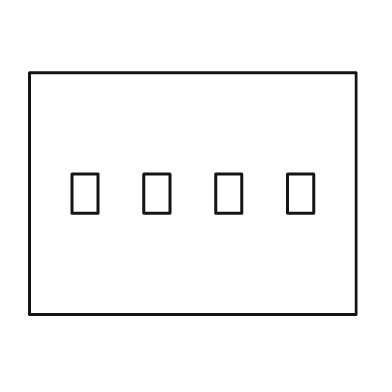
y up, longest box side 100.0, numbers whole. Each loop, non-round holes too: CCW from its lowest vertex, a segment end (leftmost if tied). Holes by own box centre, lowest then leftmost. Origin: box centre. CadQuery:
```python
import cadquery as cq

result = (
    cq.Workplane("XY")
    .moveTo(-50.0, -37.0)
    .lineTo(50.0, -37.0)
    .lineTo(50.0, 37.0)
    .lineTo(-50.0, 37.0)
    .close()
    .moveTo(-37.0, -6.0)
    .lineTo(-29.0, -6.0)
    .lineTo(-29.0, 6.0)
    .lineTo(-37.0, 6.0)
    .close()
    .moveTo(-15.0, -6.0)
    .lineTo(-7.0, -6.0)
    .lineTo(-7.0, 6.0)
    .lineTo(-15.0, 6.0)
    .close()
    .moveTo(7.0, -6.0)
    .lineTo(15.0, -6.0)
    .lineTo(15.0, 6.0)
    .lineTo(7.0, 6.0)
    .close()
    .moveTo(29.0, -6.0)
    .lineTo(37.0, -6.0)
    .lineTo(37.0, 6.0)
    .lineTo(29.0, 6.0)
    .close()
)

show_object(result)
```